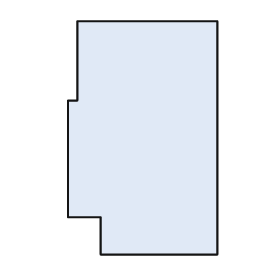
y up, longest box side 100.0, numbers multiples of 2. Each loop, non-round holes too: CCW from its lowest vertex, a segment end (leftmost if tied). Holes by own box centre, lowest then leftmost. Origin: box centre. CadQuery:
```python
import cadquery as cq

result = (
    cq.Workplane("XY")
    .moveTo(-18.0, -50.0)
    .lineTo(32.0, -50.0)
    .lineTo(32.0, 50.0)
    .lineTo(-28.0, 50.0)
    .lineTo(-28.0, 16.0)
    .lineTo(-32.0, 16.0)
    .lineTo(-32.0, -34.0)
    .lineTo(-18.0, -34.0)
    .close()
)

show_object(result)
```